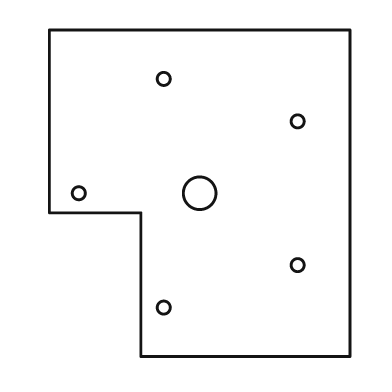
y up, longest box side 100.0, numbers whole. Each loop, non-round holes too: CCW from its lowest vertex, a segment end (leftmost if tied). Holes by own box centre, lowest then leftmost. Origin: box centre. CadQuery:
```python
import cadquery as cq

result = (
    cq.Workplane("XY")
    .moveTo(-18.0, -50.0)
    .lineTo(46.0, -50.0)
    .lineTo(46.0, 50.0)
    .lineTo(-46.0, 50.0)
    .lineTo(-46.0, -6.0)
    .lineTo(-18.0, -6.0)
    .close()
    .moveTo(-11.0, -35.0)
    .circle(2.0)
    .moveTo(30.0, -22.0)
    .circle(2.0)
    .moveTo(-37.0, 0.0)
    .circle(2.0)
    .moveTo(0.0, 0.0)
    .circle(5.0)
    .moveTo(30.0, 22.0)
    .circle(2.0)
    .moveTo(-11.0, 35.0)
    .circle(2.0)
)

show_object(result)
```